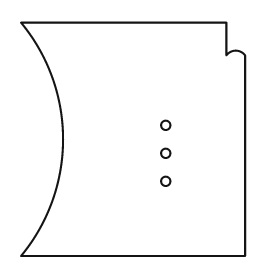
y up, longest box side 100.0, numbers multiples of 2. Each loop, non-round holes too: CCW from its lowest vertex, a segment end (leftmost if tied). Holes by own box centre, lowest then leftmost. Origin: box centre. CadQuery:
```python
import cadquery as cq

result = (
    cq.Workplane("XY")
    .moveTo(-48.0, -50.0)
    .lineTo(48.0, -50.0)
    .lineTo(48.0, 36.0)
    .threePointArc((44.0, 38.0), (40.0, 36.0))
    .lineTo(40.0, 50.0)
    .lineTo(-48.0, 50.0)
    .threePointArc((-30.0, 0.0), (-48.0, -50.0))
    .close()
    .moveTo(14.0, -18.0)
    .circle(2.0)
    .moveTo(14.0, -6.0)
    .circle(2.0)
    .moveTo(14.0, 6.0)
    .circle(2.0)
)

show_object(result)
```